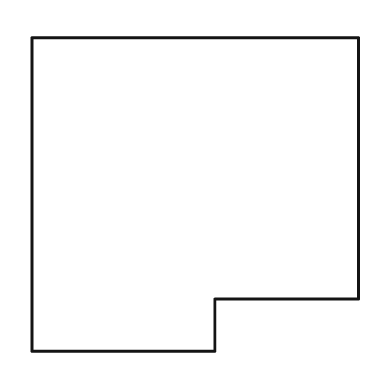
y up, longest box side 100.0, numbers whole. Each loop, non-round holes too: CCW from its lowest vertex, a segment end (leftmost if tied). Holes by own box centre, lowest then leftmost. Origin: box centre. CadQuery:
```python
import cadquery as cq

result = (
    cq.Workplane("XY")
    .moveTo(-50.0, -48.0)
    .lineTo(6.0, -48.0)
    .lineTo(6.0, -32.0)
    .lineTo(50.0, -32.0)
    .lineTo(50.0, 48.0)
    .lineTo(-50.0, 48.0)
    .close()
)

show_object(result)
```